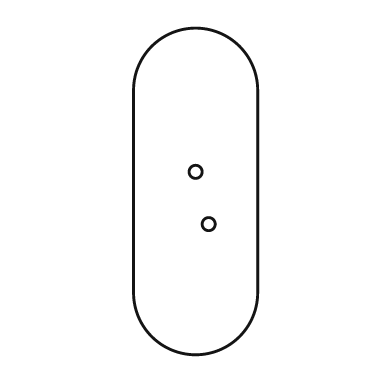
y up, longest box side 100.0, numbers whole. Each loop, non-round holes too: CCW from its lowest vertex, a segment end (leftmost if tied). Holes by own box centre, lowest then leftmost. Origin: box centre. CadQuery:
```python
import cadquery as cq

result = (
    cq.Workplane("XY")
    .moveTo(-19.0, -31.0)
    .threePointArc((0.0, -50.0), (19.0, -31.0))
    .lineTo(19.0, 31.0)
    .threePointArc((0.0, 50.0), (-19.0, 31.0))
    .close()
    .moveTo(4.0, -10.0)
    .circle(2.0)
    .moveTo(0.0, 6.0)
    .circle(2.0)
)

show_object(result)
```